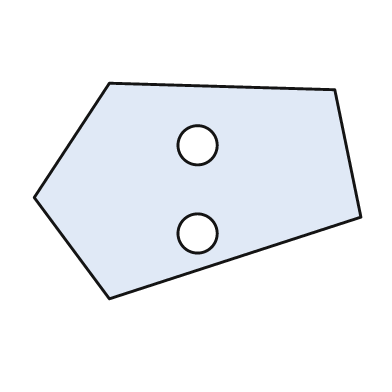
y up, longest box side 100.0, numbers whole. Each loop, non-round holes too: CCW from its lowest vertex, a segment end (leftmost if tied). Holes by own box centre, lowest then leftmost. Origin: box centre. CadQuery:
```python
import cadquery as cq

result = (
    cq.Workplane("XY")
    .moveTo(-27.0, -33.0)
    .lineTo(50.0, -8.0)
    .lineTo(42.0, 31.0)
    .lineTo(-27.0, 33.0)
    .lineTo(-50.0, -2.0)
    .close()
    .moveTo(0.0, -13.0)
    .circle(6.0)
    .moveTo(0.0, 14.0)
    .circle(6.0)
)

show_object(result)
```